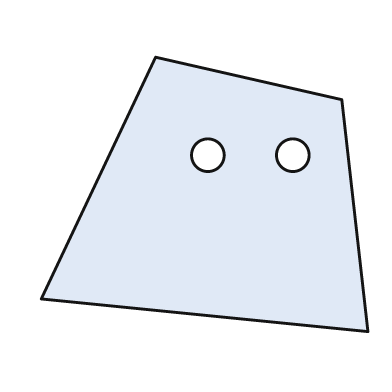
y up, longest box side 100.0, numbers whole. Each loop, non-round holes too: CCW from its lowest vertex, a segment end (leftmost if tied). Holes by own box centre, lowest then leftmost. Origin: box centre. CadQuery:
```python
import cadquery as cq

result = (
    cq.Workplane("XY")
    .moveTo(50.0, -42.0)
    .lineTo(42.0, 29.0)
    .lineTo(-15.0, 42.0)
    .lineTo(-50.0, -32.0)
    .close()
    .moveTo(1.0, 12.0)
    .circle(5.0)
    .moveTo(27.0, 12.0)
    .circle(5.0)
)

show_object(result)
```